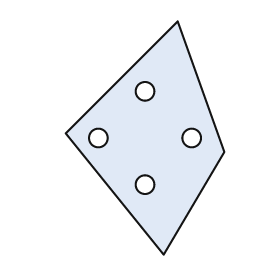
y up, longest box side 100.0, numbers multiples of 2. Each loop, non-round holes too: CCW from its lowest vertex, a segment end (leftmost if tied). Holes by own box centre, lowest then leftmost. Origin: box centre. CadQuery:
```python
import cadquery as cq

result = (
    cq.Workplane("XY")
    .moveTo(8.0, -50.0)
    .lineTo(34.0, -6.0)
    .lineTo(14.0, 50.0)
    .lineTo(-34.0, 2.0)
    .close()
    .moveTo(0.0, -20.0)
    .circle(4.0)
    .moveTo(-20.0, 0.0)
    .circle(4.0)
    .moveTo(20.0, 0.0)
    .circle(4.0)
    .moveTo(0.0, 20.0)
    .circle(4.0)
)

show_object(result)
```